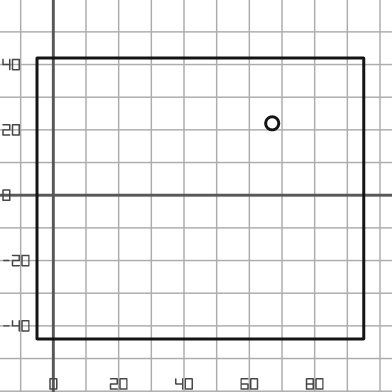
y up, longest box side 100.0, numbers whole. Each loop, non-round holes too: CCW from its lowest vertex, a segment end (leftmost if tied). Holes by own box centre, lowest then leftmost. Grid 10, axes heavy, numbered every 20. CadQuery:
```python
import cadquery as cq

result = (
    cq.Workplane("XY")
    .moveTo(-5.0, -44.0)
    .lineTo(95.0, -44.0)
    .lineTo(95.0, 42.0)
    .lineTo(-5.0, 42.0)
    .close()
    .moveTo(67.0, 22.0)
    .circle(2.0)
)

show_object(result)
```